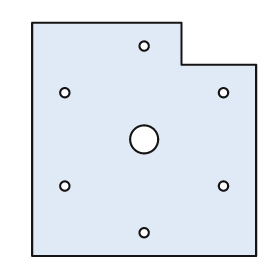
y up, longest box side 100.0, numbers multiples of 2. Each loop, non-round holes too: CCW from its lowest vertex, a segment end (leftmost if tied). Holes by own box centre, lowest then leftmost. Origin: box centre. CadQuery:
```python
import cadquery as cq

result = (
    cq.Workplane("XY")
    .moveTo(-48.0, -50.0)
    .lineTo(48.0, -50.0)
    .lineTo(48.0, 32.0)
    .lineTo(16.0, 32.0)
    .lineTo(16.0, 50.0)
    .lineTo(-48.0, 50.0)
    .close()
    .moveTo(0.0, -40.0)
    .circle(2.0)
    .moveTo(-34.0, -20.0)
    .circle(2.0)
    .moveTo(34.0, -20.0)
    .circle(2.0)
    .moveTo(0.0, 0.0)
    .circle(6.0)
    .moveTo(-34.0, 20.0)
    .circle(2.0)
    .moveTo(34.0, 20.0)
    .circle(2.0)
    .moveTo(0.0, 40.0)
    .circle(2.0)
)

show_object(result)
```